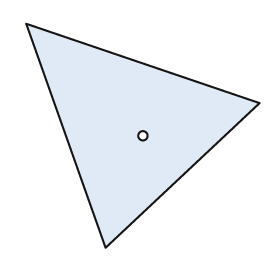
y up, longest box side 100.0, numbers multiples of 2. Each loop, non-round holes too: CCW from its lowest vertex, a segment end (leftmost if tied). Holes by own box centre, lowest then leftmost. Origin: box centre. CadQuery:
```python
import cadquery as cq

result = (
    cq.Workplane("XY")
    .moveTo(-16.0, -48.0)
    .lineTo(50.0, 14.0)
    .lineTo(-50.0, 48.0)
    .close()
    .moveTo(0.0, 0.0)
    .circle(2.0)
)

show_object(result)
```